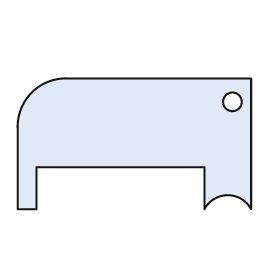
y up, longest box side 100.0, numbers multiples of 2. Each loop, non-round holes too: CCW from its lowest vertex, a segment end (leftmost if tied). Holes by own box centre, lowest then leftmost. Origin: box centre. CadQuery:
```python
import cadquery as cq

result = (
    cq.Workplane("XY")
    .moveTo(-50.0, -28.0)
    .lineTo(-42.0, -28.0)
    .lineTo(-42.0, -10.0)
    .lineTo(30.0, -10.0)
    .lineTo(30.0, -28.0)
    .threePointArc((40.0, -22.0), (50.0, -28.0))
    .lineTo(50.0, 28.0)
    .lineTo(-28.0, 28.0)
    .threePointArc((-44.0, 22.0), (-50.0, 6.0))
    .close()
    .moveTo(42.0, 18.0)
    .circle(4.0)
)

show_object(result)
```